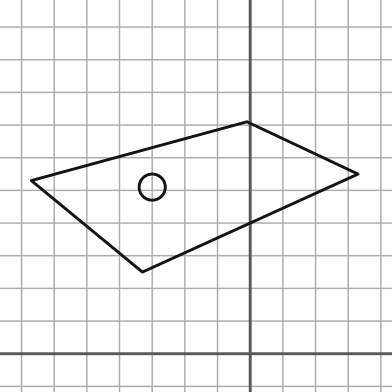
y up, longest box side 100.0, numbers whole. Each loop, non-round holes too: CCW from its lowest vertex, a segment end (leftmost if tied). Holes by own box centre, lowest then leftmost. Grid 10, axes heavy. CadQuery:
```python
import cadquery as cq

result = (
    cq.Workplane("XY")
    .moveTo(-33.0, 25.0)
    .lineTo(33.0, 55.0)
    .lineTo(-1.0, 71.0)
    .lineTo(-67.0, 53.0)
    .close()
    .moveTo(-30.0, 51.0)
    .circle(4.0)
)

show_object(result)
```